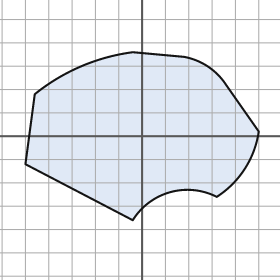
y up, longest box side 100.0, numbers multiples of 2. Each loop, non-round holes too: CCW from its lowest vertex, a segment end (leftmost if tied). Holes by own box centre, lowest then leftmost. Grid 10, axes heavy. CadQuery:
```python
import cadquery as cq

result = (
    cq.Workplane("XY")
    .moveTo(-4.0, -36.0)
    .threePointArc((12.0, -24.0), (32.0, -26.0))
    .threePointArc((44.0, -14.0), (50.0, 2.0))
    .lineTo(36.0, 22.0)
    .threePointArc((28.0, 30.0), (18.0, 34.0))
    .lineTo(-4.0, 36.0)
    .threePointArc((-26.0, 30.0), (-46.0, 18.0))
    .lineTo(-50.0, -12.0)
    .close()
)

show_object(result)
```